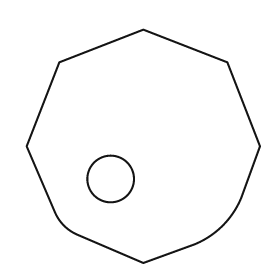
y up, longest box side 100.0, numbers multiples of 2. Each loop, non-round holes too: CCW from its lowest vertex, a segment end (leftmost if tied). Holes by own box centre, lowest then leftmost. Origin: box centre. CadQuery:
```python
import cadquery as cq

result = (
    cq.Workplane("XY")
    .moveTo(0.0, -50.0)
    .lineTo(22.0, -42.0)
    .threePointArc((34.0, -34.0), (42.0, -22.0))
    .lineTo(50.0, 0.0)
    .lineTo(36.0, 36.0)
    .lineTo(0.0, 50.0)
    .lineTo(-36.0, 36.0)
    .lineTo(-50.0, 0.0)
    .lineTo(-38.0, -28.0)
    .threePointArc((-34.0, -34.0), (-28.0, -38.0))
    .close()
    .moveTo(-14.0, -14.0)
    .circle(10.0)
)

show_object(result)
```